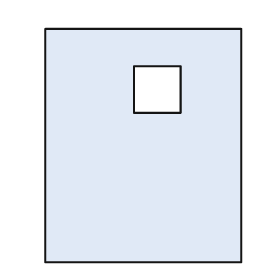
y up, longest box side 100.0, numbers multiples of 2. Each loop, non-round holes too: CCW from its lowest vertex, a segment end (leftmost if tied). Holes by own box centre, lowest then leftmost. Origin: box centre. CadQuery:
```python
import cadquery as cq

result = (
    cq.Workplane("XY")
    .moveTo(-42.0, -50.0)
    .lineTo(42.0, -50.0)
    .lineTo(42.0, 50.0)
    .lineTo(-42.0, 50.0)
    .close()
    .moveTo(-4.0, 14.0)
    .lineTo(16.0, 14.0)
    .lineTo(16.0, 34.0)
    .lineTo(-4.0, 34.0)
    .close()
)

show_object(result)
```